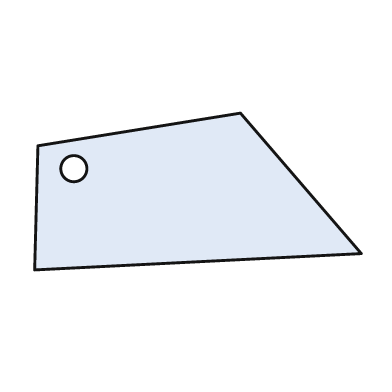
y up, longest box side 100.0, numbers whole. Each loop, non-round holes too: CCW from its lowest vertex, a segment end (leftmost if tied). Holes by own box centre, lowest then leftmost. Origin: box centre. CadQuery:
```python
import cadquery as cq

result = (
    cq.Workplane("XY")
    .moveTo(-50.0, -24.0)
    .lineTo(50.0, -19.0)
    .lineTo(13.0, 24.0)
    .lineTo(-49.0, 14.0)
    .close()
    .moveTo(-38.0, 7.0)
    .circle(4.0)
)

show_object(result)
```